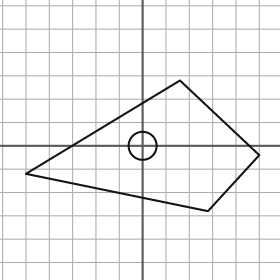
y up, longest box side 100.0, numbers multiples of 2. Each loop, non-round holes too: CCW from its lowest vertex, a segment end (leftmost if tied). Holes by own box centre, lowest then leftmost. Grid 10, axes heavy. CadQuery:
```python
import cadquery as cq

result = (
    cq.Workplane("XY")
    .moveTo(28.0, -28.0)
    .lineTo(50.0, -4.0)
    .lineTo(16.0, 28.0)
    .lineTo(-50.0, -12.0)
    .close()
    .moveTo(0.0, 0.0)
    .circle(6.0)
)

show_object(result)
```